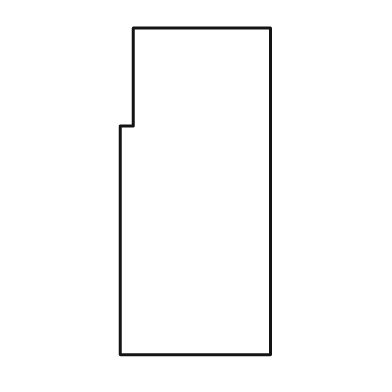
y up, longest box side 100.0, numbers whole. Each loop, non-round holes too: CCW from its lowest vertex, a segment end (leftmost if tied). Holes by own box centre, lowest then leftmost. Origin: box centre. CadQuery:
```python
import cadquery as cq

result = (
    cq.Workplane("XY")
    .moveTo(-23.0, -50.0)
    .lineTo(23.0, -50.0)
    .lineTo(23.0, 50.0)
    .lineTo(-19.0, 50.0)
    .lineTo(-19.0, 20.0)
    .lineTo(-23.0, 20.0)
    .close()
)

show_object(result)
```